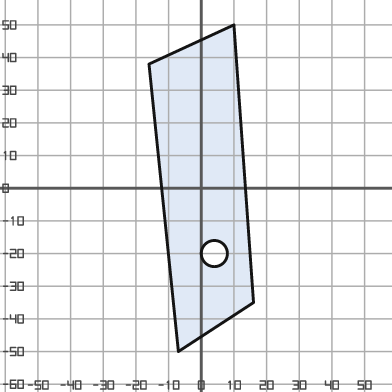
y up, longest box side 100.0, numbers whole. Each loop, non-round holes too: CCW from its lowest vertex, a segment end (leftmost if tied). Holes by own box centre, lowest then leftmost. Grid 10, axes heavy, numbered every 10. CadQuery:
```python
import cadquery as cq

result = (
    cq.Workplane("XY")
    .moveTo(-7.0, -50.0)
    .lineTo(16.0, -35.0)
    .lineTo(10.0, 50.0)
    .lineTo(-16.0, 38.0)
    .close()
    .moveTo(4.0, -20.0)
    .circle(4.0)
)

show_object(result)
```